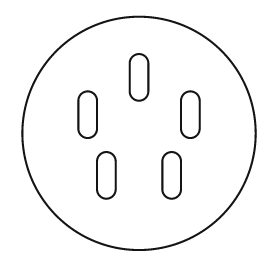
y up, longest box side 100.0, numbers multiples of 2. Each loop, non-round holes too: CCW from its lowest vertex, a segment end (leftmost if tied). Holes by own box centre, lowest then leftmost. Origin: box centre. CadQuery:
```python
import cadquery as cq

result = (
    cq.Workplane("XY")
    .moveTo(0.0, 0.0)
    .circle(50.0)
    .moveTo(-18.0, -24.0)
    .threePointArc((-14.0, -28.0), (-10.0, -24.0))
    .lineTo(-10.0, -12.0)
    .threePointArc((-14.0, -8.0), (-18.0, -12.0))
    .close()
    .moveTo(10.0, -24.0)
    .threePointArc((14.0, -28.0), (18.0, -24.0))
    .lineTo(18.0, -12.0)
    .threePointArc((14.0, -8.0), (10.0, -12.0))
    .close()
    .moveTo(-26.0, 2.0)
    .threePointArc((-22.0, -2.0), (-18.0, 2.0))
    .lineTo(-18.0, 14.0)
    .threePointArc((-22.0, 18.0), (-26.0, 14.0))
    .close()
    .moveTo(18.0, 2.0)
    .threePointArc((22.0, -2.0), (26.0, 2.0))
    .lineTo(26.0, 14.0)
    .threePointArc((22.0, 18.0), (18.0, 14.0))
    .close()
    .moveTo(-4.0, 18.0)
    .threePointArc((0.0, 14.0), (4.0, 18.0))
    .lineTo(4.0, 30.0)
    .threePointArc((0.0, 34.0), (-4.0, 30.0))
    .close()
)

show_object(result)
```